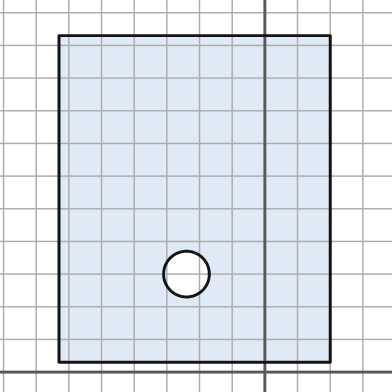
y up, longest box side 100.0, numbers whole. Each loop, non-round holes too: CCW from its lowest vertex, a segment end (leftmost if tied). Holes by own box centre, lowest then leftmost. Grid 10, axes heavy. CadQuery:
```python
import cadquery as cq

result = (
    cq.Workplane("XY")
    .moveTo(-63.0, 3.0)
    .lineTo(20.0, 3.0)
    .lineTo(20.0, 103.0)
    .lineTo(-63.0, 103.0)
    .close()
    .moveTo(-24.0, 30.0)
    .circle(7.0)
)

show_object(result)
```